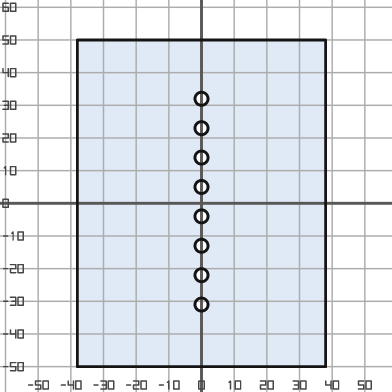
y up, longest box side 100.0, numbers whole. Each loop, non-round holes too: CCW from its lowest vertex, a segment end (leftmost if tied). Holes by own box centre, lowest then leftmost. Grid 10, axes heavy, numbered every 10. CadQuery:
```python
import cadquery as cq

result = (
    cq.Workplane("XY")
    .moveTo(-38.0, -50.0)
    .lineTo(38.0, -50.0)
    .lineTo(38.0, 50.0)
    .lineTo(-38.0, 50.0)
    .close()
    .moveTo(0.0, -31.0)
    .circle(2.0)
    .moveTo(0.0, -22.0)
    .circle(2.0)
    .moveTo(0.0, -13.0)
    .circle(2.0)
    .moveTo(0.0, -4.0)
    .circle(2.0)
    .moveTo(0.0, 5.0)
    .circle(2.0)
    .moveTo(0.0, 14.0)
    .circle(2.0)
    .moveTo(0.0, 23.0)
    .circle(2.0)
    .moveTo(0.0, 32.0)
    .circle(2.0)
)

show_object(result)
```